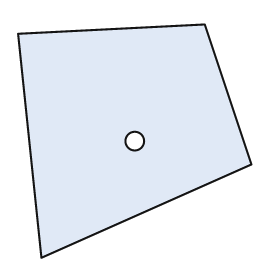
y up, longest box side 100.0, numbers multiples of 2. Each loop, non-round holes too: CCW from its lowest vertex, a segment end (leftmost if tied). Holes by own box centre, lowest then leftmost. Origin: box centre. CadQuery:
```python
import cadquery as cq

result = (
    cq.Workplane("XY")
    .moveTo(-40.0, -50.0)
    .lineTo(50.0, -10.0)
    .lineTo(30.0, 50.0)
    .lineTo(-50.0, 46.0)
    .close()
    .moveTo(0.0, 0.0)
    .circle(4.0)
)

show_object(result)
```